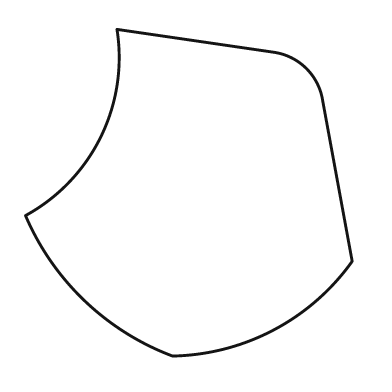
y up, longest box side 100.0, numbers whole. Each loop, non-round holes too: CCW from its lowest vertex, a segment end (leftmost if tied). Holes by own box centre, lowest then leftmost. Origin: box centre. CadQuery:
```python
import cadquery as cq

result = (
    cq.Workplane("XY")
    .moveTo(-5.0, -50.0)
    .threePointArc((26.0, -42.0), (50.0, -21.0))
    .lineTo(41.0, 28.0)
    .threePointArc((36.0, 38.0), (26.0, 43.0))
    .lineTo(-22.0, 50.0)
    .threePointArc((-27.0, 17.0), (-50.0, -7.0))
    .threePointArc((-32.0, -33.0), (-5.0, -50.0))
    .close()
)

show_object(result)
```